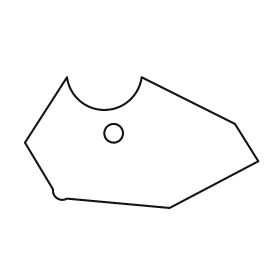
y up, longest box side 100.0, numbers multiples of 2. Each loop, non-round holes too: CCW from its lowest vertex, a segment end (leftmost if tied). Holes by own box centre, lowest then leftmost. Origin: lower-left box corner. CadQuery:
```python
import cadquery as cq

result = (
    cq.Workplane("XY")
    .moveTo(62.0, 0.0)
    .lineTo(100.0, 20.0)
    .lineTo(90.0, 36.0)
    .lineTo(50.0, 56.0)
    .threePointArc((34.0, 42.0), (18.0, 56.0))
    .lineTo(0.0, 28.0)
    .lineTo(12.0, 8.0)
    .threePointArc((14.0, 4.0), (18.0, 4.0))
    .close()
    .moveTo(38.0, 32.0)
    .circle(4.0)
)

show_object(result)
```